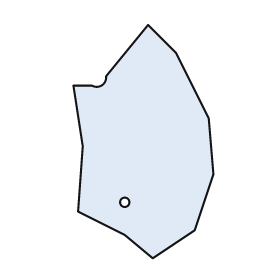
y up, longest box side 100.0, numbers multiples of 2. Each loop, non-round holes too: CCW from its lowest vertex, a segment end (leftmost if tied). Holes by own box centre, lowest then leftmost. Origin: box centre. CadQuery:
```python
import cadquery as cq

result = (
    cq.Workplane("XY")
    .moveTo(4.0, -50.0)
    .lineTo(22.0, -38.0)
    .lineTo(30.0, -14.0)
    .lineTo(28.0, 10.0)
    .lineTo(14.0, 38.0)
    .lineTo(2.0, 50.0)
    .lineTo(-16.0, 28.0)
    .threePointArc((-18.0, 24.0), (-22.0, 24.0))
    .lineTo(-30.0, 24.0)
    .lineTo(-26.0, -2.0)
    .lineTo(-28.0, -30.0)
    .lineTo(-8.0, -40.0)
    .close()
    .moveTo(-8.0, -26.0)
    .circle(2.0)
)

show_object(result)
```